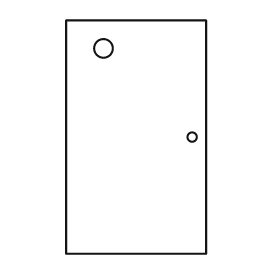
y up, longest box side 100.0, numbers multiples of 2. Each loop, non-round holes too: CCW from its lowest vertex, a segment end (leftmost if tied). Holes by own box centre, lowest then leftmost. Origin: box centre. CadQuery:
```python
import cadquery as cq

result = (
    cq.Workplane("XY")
    .moveTo(-30.0, -50.0)
    .lineTo(30.0, -50.0)
    .lineTo(30.0, 50.0)
    .lineTo(-30.0, 50.0)
    .close()
    .moveTo(24.0, 0.0)
    .circle(2.0)
    .moveTo(-14.0, 38.0)
    .circle(4.0)
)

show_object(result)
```